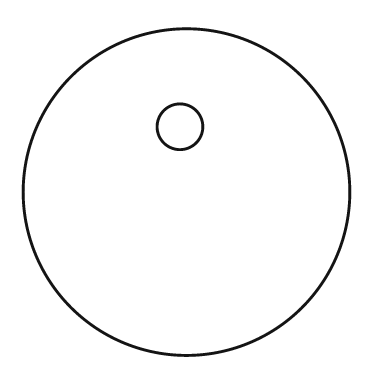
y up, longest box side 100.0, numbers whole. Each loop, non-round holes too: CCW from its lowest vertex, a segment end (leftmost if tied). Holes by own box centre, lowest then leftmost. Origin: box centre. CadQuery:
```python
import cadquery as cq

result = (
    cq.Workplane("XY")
    .moveTo(0.0, 0.0)
    .circle(50.0)
    .moveTo(-2.0, 20.0)
    .circle(7.0)
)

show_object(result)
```